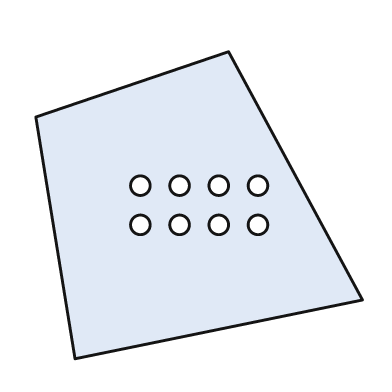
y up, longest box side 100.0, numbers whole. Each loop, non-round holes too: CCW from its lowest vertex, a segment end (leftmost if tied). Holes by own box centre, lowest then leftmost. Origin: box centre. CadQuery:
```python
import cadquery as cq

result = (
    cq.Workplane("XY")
    .moveTo(-38.0, -47.0)
    .lineTo(50.0, -29.0)
    .lineTo(9.0, 47.0)
    .lineTo(-50.0, 27.0)
    .close()
    .moveTo(-18.0, -6.0)
    .circle(3.0)
    .moveTo(-6.0, -6.0)
    .circle(3.0)
    .moveTo(6.0, -6.0)
    .circle(3.0)
    .moveTo(18.0, -6.0)
    .circle(3.0)
    .moveTo(-18.0, 6.0)
    .circle(3.0)
    .moveTo(-6.0, 6.0)
    .circle(3.0)
    .moveTo(6.0, 6.0)
    .circle(3.0)
    .moveTo(18.0, 6.0)
    .circle(3.0)
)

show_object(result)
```